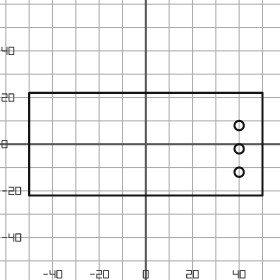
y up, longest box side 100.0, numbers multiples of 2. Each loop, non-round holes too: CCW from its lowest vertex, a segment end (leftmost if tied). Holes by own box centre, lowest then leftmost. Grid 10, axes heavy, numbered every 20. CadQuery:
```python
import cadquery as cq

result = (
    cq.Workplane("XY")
    .moveTo(-50.0, -22.0)
    .lineTo(50.0, -22.0)
    .lineTo(50.0, 22.0)
    .lineTo(-50.0, 22.0)
    .close()
    .moveTo(40.0, -12.0)
    .circle(2.0)
    .moveTo(40.0, -2.0)
    .circle(2.0)
    .moveTo(40.0, 8.0)
    .circle(2.0)
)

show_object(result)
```